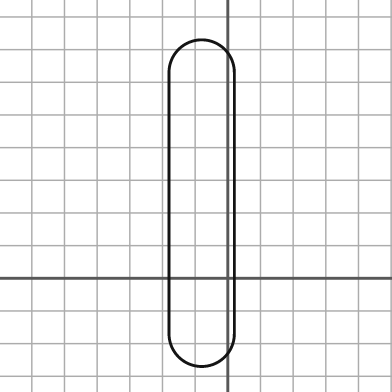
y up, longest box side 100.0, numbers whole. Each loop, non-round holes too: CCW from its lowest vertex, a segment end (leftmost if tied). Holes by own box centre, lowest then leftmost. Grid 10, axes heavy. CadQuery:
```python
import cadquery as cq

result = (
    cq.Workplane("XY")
    .moveTo(-18.0, -17.0)
    .threePointArc((-8.0, -27.0), (2.0, -17.0))
    .lineTo(2.0, 63.0)
    .threePointArc((-8.0, 73.0), (-18.0, 63.0))
    .close()
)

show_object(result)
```